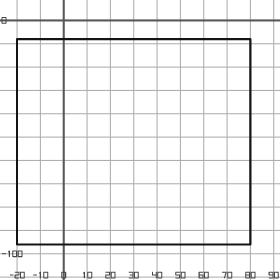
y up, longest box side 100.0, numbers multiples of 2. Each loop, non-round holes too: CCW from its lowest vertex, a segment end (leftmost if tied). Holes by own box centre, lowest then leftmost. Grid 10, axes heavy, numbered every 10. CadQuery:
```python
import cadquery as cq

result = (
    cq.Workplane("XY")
    .moveTo(-20.0, -96.0)
    .lineTo(80.0, -96.0)
    .lineTo(80.0, -8.0)
    .lineTo(-20.0, -8.0)
    .close()
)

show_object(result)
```